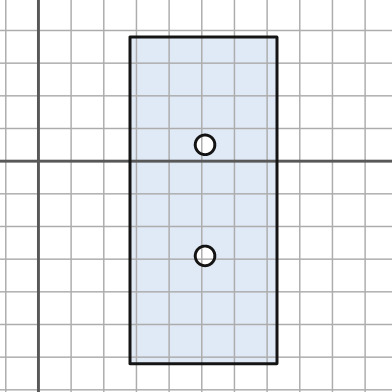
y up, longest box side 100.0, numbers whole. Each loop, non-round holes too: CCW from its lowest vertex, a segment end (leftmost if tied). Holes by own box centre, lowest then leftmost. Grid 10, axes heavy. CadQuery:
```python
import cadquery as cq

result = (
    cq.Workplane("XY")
    .moveTo(28.0, -62.0)
    .lineTo(73.0, -62.0)
    .lineTo(73.0, 38.0)
    .lineTo(28.0, 38.0)
    .close()
    .moveTo(51.0, -29.0)
    .circle(3.0)
    .moveTo(51.0, 5.0)
    .circle(3.0)
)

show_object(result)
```